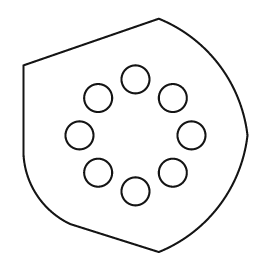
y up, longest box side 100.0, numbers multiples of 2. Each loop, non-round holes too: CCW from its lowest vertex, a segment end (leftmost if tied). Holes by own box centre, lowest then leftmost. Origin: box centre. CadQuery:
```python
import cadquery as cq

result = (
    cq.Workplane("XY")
    .moveTo(10.0, -50.0)
    .threePointArc((36.0, -30.0), (48.0, 0.0))
    .threePointArc((36.0, 30.0), (10.0, 50.0))
    .lineTo(-48.0, 30.0)
    .lineTo(-48.0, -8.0)
    .threePointArc((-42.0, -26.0), (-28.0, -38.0))
    .close()
    .moveTo(0.0, -24.0)
    .circle(6.0)
    .moveTo(-16.0, -16.0)
    .circle(6.0)
    .moveTo(16.0, -16.0)
    .circle(6.0)
    .moveTo(-24.0, 0.0)
    .circle(6.0)
    .moveTo(24.0, 0.0)
    .circle(6.0)
    .moveTo(-16.0, 16.0)
    .circle(6.0)
    .moveTo(16.0, 16.0)
    .circle(6.0)
    .moveTo(0.0, 24.0)
    .circle(6.0)
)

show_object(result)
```